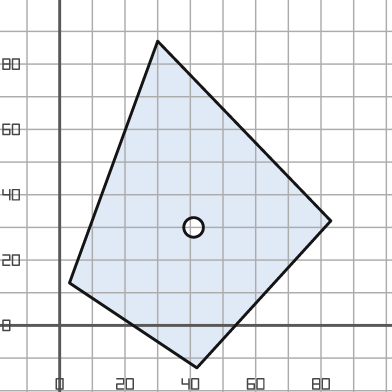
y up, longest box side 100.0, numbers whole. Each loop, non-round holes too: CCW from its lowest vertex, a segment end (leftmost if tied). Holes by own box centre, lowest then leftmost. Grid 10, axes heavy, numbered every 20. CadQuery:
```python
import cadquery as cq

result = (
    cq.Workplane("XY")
    .moveTo(42.0, -13.0)
    .lineTo(83.0, 32.0)
    .lineTo(30.0, 87.0)
    .lineTo(3.0, 13.0)
    .close()
    .moveTo(41.0, 30.0)
    .circle(3.0)
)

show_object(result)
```